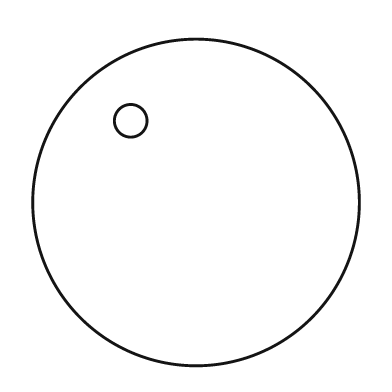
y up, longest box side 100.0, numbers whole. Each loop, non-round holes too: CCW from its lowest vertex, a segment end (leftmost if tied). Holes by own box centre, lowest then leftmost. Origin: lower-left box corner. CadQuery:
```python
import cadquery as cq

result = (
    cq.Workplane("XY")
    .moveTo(50.0, 50.0)
    .circle(50.0)
    .moveTo(30.0, 75.0)
    .circle(5.0)
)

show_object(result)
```